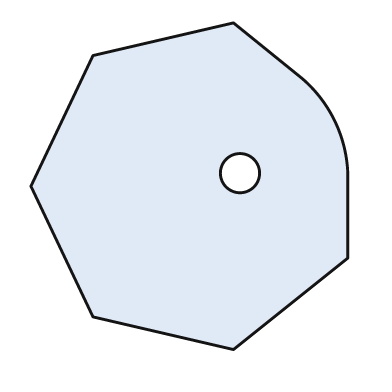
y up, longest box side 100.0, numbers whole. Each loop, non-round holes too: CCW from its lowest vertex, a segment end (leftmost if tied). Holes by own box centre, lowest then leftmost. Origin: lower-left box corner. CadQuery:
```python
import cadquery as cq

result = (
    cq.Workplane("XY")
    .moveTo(62.0, 0.0)
    .lineTo(97.0, 28.0)
    .lineTo(97.0, 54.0)
    .threePointArc((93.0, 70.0), (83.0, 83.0))
    .lineTo(62.0, 100.0)
    .lineTo(19.0, 90.0)
    .lineTo(0.0, 50.0)
    .lineTo(19.0, 10.0)
    .close()
    .moveTo(64.0, 54.0)
    .circle(6.0)
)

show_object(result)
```